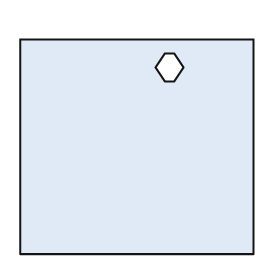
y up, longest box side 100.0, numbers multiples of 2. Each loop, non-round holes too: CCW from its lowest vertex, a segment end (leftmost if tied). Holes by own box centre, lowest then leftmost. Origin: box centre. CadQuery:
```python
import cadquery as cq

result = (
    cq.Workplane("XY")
    .moveTo(-50.0, -46.0)
    .lineTo(50.0, -46.0)
    .lineTo(50.0, 46.0)
    .lineTo(-50.0, 46.0)
    .close()
    .moveTo(12.0, 28.0)
    .lineTo(16.0, 28.0)
    .lineTo(20.0, 34.0)
    .lineTo(16.0, 40.0)
    .lineTo(12.0, 40.0)
    .lineTo(8.0, 34.0)
    .close()
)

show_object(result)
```